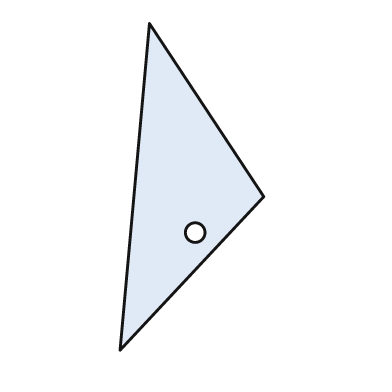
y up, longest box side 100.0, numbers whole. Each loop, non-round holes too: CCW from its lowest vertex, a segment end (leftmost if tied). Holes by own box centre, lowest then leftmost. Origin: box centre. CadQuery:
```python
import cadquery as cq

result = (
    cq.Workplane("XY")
    .moveTo(-22.0, -50.0)
    .lineTo(22.0, -3.0)
    .lineTo(-13.0, 50.0)
    .close()
    .moveTo(1.0, -14.0)
    .circle(3.0)
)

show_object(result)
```